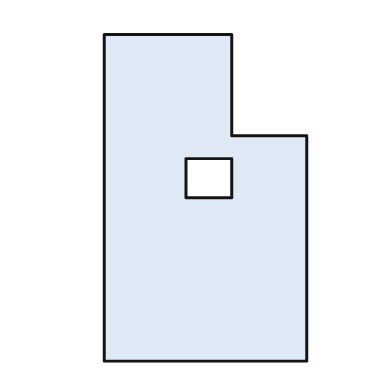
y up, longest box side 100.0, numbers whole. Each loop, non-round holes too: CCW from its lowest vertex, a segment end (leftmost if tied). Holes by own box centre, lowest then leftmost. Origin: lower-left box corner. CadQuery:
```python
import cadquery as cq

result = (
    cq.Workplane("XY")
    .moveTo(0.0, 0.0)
    .lineTo(62.0, 0.0)
    .lineTo(62.0, 69.0)
    .lineTo(39.0, 69.0)
    .lineTo(39.0, 100.0)
    .lineTo(0.0, 100.0)
    .close()
    .moveTo(25.0, 50.0)
    .lineTo(39.0, 50.0)
    .lineTo(39.0, 62.0)
    .lineTo(25.0, 62.0)
    .close()
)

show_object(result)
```